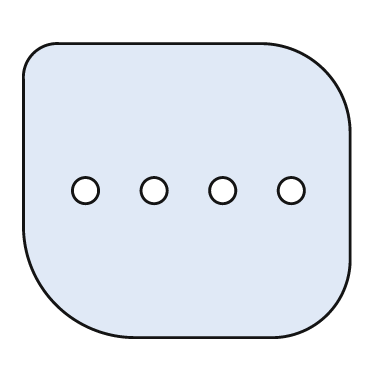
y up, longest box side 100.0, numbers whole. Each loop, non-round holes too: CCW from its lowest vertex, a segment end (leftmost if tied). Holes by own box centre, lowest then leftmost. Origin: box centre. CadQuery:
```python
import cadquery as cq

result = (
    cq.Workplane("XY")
    .moveTo(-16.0, -45.0)
    .lineTo(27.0, -45.0)
    .threePointArc((43.0, -38.0), (50.0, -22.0))
    .lineTo(50.0, 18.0)
    .threePointArc((42.0, 37.0), (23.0, 45.0))
    .lineTo(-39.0, 45.0)
    .threePointArc((-47.0, 42.0), (-50.0, 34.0))
    .lineTo(-50.0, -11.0)
    .threePointArc((-40.0, -35.0), (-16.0, -45.0))
    .close()
    .moveTo(-31.0, 0.0)
    .circle(4.0)
    .moveTo(-10.0, 0.0)
    .circle(4.0)
    .moveTo(11.0, 0.0)
    .circle(4.0)
    .moveTo(32.0, 0.0)
    .circle(4.0)
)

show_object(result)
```